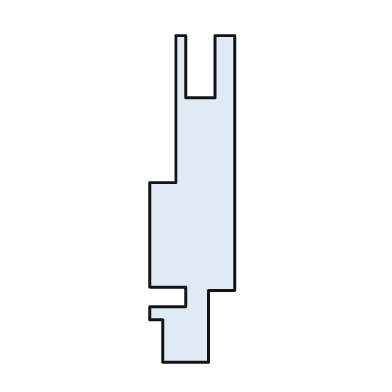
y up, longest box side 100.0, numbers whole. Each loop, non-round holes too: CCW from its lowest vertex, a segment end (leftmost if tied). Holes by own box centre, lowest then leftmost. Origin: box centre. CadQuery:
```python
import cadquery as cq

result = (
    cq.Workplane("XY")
    .moveTo(-9.0, -50.0)
    .lineTo(5.0, -50.0)
    .lineTo(5.0, -28.0)
    .lineTo(13.0, -28.0)
    .lineTo(13.0, 50.0)
    .lineTo(7.0, 50.0)
    .lineTo(7.0, 31.0)
    .lineTo(-2.0, 31.0)
    .lineTo(-2.0, 50.0)
    .lineTo(-5.0, 50.0)
    .lineTo(-5.0, 5.0)
    .lineTo(-13.0, 5.0)
    .lineTo(-13.0, -27.0)
    .lineTo(-2.0, -27.0)
    .lineTo(-2.0, -33.0)
    .lineTo(-13.0, -33.0)
    .lineTo(-13.0, -37.0)
    .lineTo(-9.0, -37.0)
    .close()
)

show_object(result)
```